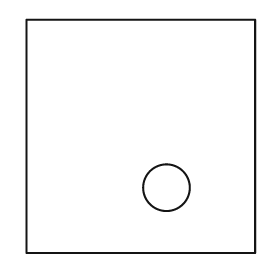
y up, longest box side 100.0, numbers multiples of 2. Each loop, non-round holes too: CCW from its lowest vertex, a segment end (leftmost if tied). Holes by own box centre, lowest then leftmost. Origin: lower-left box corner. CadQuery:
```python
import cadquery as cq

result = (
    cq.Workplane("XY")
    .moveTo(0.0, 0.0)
    .lineTo(98.0, 0.0)
    .lineTo(98.0, 100.0)
    .lineTo(0.0, 100.0)
    .close()
    .moveTo(60.0, 28.0)
    .circle(10.0)
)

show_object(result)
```